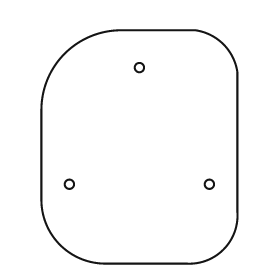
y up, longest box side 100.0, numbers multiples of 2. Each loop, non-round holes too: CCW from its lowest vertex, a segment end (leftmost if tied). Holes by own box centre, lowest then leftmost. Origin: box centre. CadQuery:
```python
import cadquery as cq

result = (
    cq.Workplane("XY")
    .moveTo(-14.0, -50.0)
    .lineTo(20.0, -50.0)
    .threePointArc((36.0, -44.0), (42.0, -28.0))
    .lineTo(42.0, 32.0)
    .threePointArc((36.0, 44.0), (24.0, 50.0))
    .lineTo(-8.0, 50.0)
    .threePointArc((-32.0, 40.0), (-42.0, 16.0))
    .lineTo(-42.0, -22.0)
    .threePointArc((-34.0, -42.0), (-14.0, -50.0))
    .close()
    .moveTo(-30.0, -16.0)
    .circle(2.0)
    .moveTo(30.0, -16.0)
    .circle(2.0)
    .moveTo(0.0, 34.0)
    .circle(2.0)
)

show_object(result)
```